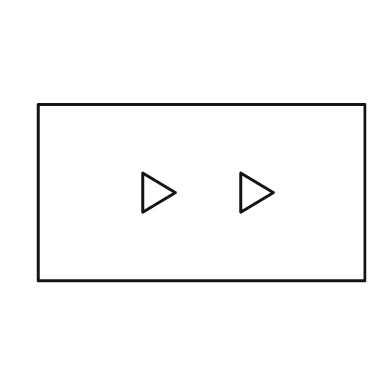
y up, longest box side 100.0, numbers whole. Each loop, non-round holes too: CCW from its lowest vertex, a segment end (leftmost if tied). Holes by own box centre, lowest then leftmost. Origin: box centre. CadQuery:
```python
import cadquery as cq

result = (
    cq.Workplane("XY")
    .moveTo(-50.0, -27.0)
    .lineTo(50.0, -27.0)
    .lineTo(50.0, 27.0)
    .lineTo(-50.0, 27.0)
    .close()
    .moveTo(-18.0, -6.0)
    .lineTo(-8.0, 0.0)
    .lineTo(-18.0, 6.0)
    .close()
    .moveTo(12.0, -6.0)
    .lineTo(22.0, 0.0)
    .lineTo(12.0, 6.0)
    .close()
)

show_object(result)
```